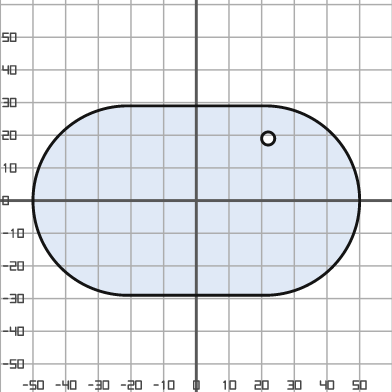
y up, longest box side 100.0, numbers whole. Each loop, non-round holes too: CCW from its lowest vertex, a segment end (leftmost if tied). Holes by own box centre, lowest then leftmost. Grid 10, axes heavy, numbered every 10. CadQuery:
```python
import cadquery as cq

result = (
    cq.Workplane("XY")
    .moveTo(-21.0, -29.0)
    .lineTo(21.0, -29.0)
    .threePointArc((50.0, 0.0), (21.0, 29.0))
    .lineTo(-21.0, 29.0)
    .threePointArc((-50.0, 0.0), (-21.0, -29.0))
    .close()
    .moveTo(22.0, 19.0)
    .circle(2.0)
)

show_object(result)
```